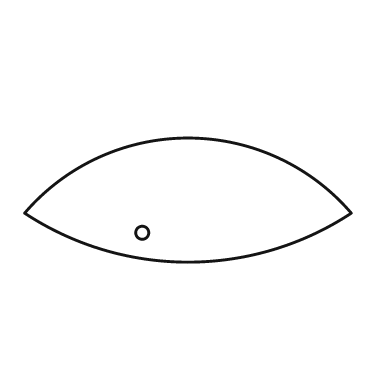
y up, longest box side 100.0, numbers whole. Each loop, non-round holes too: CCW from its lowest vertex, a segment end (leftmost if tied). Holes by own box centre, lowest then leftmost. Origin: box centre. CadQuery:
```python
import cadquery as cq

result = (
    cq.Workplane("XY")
    .moveTo(-50.0, -4.0)
    .threePointArc((0.0, -19.0), (50.0, -4.0))
    .threePointArc((0.0, 19.0), (-50.0, -4.0))
    .close()
    .moveTo(-14.0, -10.0)
    .circle(2.0)
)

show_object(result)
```